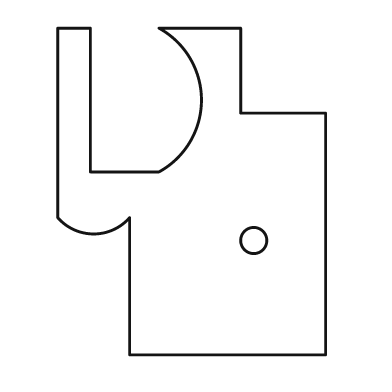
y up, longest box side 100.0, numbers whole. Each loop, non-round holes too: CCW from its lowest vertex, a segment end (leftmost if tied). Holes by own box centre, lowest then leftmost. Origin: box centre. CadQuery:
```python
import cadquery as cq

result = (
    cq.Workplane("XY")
    .moveTo(-19.0, -50.0)
    .lineTo(41.0, -50.0)
    .lineTo(41.0, 24.0)
    .lineTo(15.0, 24.0)
    .lineTo(15.0, 50.0)
    .lineTo(-10.0, 50.0)
    .threePointArc((3.0, 28.0), (-10.0, 6.0))
    .lineTo(-31.0, 6.0)
    .lineTo(-31.0, 50.0)
    .lineTo(-41.0, 50.0)
    .lineTo(-41.0, -8.0)
    .threePointArc((-30.0, -13.0), (-19.0, -8.0))
    .close()
    .moveTo(19.0, -15.0)
    .circle(4.0)
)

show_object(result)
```